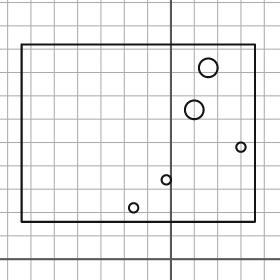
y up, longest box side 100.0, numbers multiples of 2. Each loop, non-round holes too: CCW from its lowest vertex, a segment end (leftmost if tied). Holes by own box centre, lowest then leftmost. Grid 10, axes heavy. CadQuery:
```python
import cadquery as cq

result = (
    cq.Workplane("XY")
    .moveTo(-64.0, 16.0)
    .lineTo(36.0, 16.0)
    .lineTo(36.0, 92.0)
    .lineTo(-64.0, 92.0)
    .close()
    .moveTo(-16.0, 22.0)
    .circle(2.0)
    .moveTo(-2.0, 34.0)
    .circle(2.0)
    .moveTo(30.0, 48.0)
    .circle(2.0)
    .moveTo(10.0, 64.0)
    .circle(4.0)
    .moveTo(16.0, 82.0)
    .circle(4.0)
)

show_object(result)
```